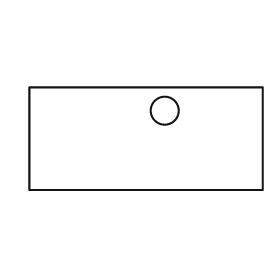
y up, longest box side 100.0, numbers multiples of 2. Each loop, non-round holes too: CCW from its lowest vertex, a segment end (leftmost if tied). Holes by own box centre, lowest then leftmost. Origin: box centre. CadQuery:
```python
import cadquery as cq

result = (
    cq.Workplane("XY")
    .moveTo(-50.0, -22.0)
    .lineTo(50.0, -22.0)
    .lineTo(50.0, 22.0)
    .lineTo(-50.0, 22.0)
    .close()
    .moveTo(8.0, 12.0)
    .circle(6.0)
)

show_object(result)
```